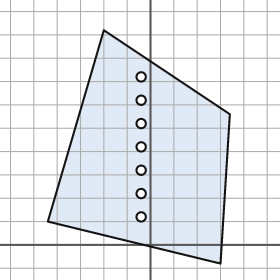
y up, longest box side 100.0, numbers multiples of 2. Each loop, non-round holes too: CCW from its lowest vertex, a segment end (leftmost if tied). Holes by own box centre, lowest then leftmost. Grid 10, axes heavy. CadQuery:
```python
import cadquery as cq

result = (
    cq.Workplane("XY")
    .moveTo(30.0, -8.0)
    .lineTo(34.0, 56.0)
    .lineTo(-20.0, 92.0)
    .lineTo(-44.0, 10.0)
    .close()
    .moveTo(-4.0, 12.0)
    .circle(2.0)
    .moveTo(-4.0, 22.0)
    .circle(2.0)
    .moveTo(-4.0, 32.0)
    .circle(2.0)
    .moveTo(-4.0, 42.0)
    .circle(2.0)
    .moveTo(-4.0, 52.0)
    .circle(2.0)
    .moveTo(-4.0, 62.0)
    .circle(2.0)
    .moveTo(-4.0, 72.0)
    .circle(2.0)
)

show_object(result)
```